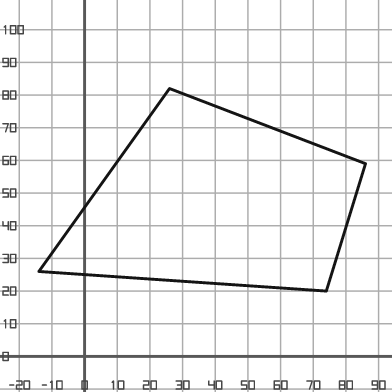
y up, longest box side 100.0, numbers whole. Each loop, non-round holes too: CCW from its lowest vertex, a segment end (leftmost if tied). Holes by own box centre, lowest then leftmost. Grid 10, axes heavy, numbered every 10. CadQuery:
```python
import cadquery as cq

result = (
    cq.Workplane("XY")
    .moveTo(74.0, 20.0)
    .lineTo(86.0, 59.0)
    .lineTo(26.0, 82.0)
    .lineTo(-14.0, 26.0)
    .close()
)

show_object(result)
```